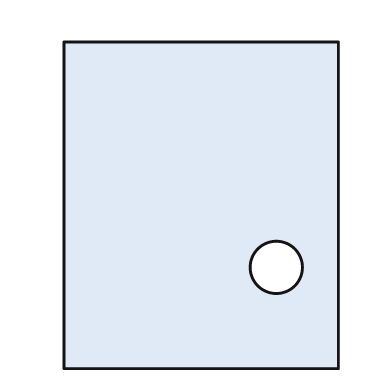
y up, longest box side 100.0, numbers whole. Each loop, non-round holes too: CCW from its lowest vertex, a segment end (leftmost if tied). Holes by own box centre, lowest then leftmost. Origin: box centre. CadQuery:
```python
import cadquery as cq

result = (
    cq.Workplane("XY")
    .moveTo(-42.0, -50.0)
    .lineTo(42.0, -50.0)
    .lineTo(42.0, 50.0)
    .lineTo(-42.0, 50.0)
    .close()
    .moveTo(23.0, -19.0)
    .circle(8.0)
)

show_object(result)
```